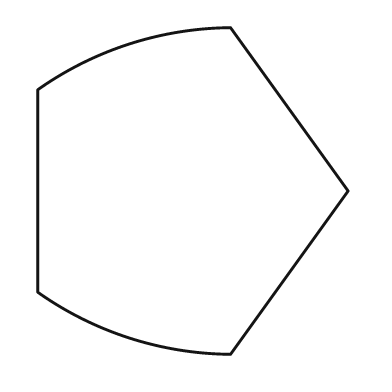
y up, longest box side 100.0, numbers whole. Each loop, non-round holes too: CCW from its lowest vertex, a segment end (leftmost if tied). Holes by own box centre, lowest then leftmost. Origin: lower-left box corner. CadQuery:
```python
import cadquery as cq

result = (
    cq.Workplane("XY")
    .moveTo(59.0, 0.0)
    .lineTo(95.0, 50.0)
    .lineTo(59.0, 100.0)
    .threePointArc((28.0, 95.0), (0.0, 81.0))
    .lineTo(0.0, 19.0)
    .threePointArc((28.0, 5.0), (59.0, 0.0))
    .close()
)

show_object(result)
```